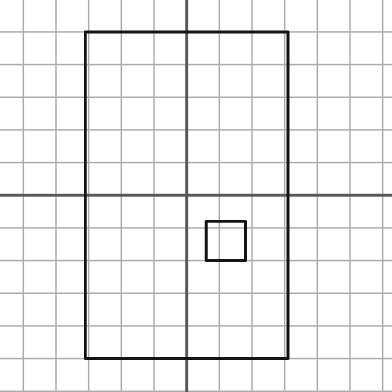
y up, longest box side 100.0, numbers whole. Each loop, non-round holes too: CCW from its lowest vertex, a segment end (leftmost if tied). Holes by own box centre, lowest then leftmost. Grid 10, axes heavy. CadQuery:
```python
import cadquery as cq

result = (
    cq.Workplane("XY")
    .moveTo(-31.0, -50.0)
    .lineTo(31.0, -50.0)
    .lineTo(31.0, 50.0)
    .lineTo(-31.0, 50.0)
    .close()
    .moveTo(6.0, -20.0)
    .lineTo(18.0, -20.0)
    .lineTo(18.0, -8.0)
    .lineTo(6.0, -8.0)
    .close()
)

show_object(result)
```